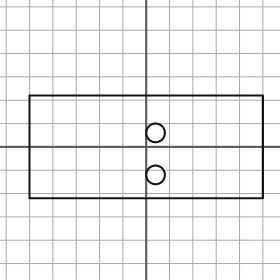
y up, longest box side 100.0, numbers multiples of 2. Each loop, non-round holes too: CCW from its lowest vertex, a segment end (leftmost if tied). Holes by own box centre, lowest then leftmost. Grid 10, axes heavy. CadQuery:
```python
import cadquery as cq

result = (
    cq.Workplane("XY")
    .moveTo(-50.0, -22.0)
    .lineTo(50.0, -22.0)
    .lineTo(50.0, 22.0)
    .lineTo(-50.0, 22.0)
    .close()
    .moveTo(4.0, -12.0)
    .circle(4.0)
    .moveTo(4.0, 6.0)
    .circle(4.0)
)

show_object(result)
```